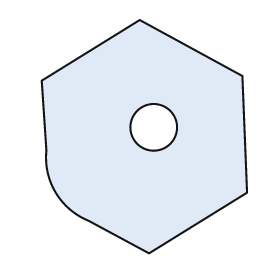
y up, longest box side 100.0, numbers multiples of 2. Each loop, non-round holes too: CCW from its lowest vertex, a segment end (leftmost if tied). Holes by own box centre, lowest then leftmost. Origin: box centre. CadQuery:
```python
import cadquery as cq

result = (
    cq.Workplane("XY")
    .moveTo(2.0, -50.0)
    .lineTo(44.0, -24.0)
    .lineTo(42.0, 26.0)
    .lineTo(-2.0, 50.0)
    .lineTo(-44.0, 24.0)
    .lineTo(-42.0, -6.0)
    .threePointArc((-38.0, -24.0), (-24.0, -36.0))
    .close()
    .moveTo(4.0, 4.0)
    .circle(10.0)
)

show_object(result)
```